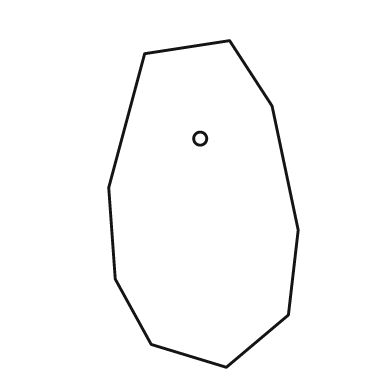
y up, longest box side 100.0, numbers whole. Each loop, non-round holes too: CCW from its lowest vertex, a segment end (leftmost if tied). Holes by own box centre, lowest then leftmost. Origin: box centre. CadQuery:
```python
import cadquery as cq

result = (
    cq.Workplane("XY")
    .moveTo(7.0, -50.0)
    .lineTo(26.0, -34.0)
    .lineTo(29.0, -8.0)
    .lineTo(21.0, 30.0)
    .lineTo(8.0, 50.0)
    .lineTo(-18.0, 46.0)
    .lineTo(-29.0, 5.0)
    .lineTo(-27.0, -23.0)
    .lineTo(-16.0, -43.0)
    .close()
    .moveTo(-1.0, 20.0)
    .circle(2.0)
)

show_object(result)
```